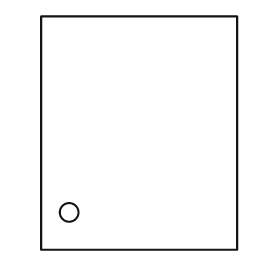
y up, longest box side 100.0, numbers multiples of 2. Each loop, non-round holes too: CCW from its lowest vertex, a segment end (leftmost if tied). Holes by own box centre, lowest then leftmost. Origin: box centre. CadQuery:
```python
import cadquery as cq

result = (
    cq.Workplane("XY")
    .moveTo(-42.0, -50.0)
    .lineTo(42.0, -50.0)
    .lineTo(42.0, 50.0)
    .lineTo(-42.0, 50.0)
    .close()
    .moveTo(-30.0, -34.0)
    .circle(4.0)
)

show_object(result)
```